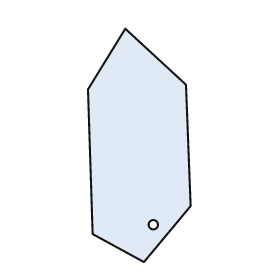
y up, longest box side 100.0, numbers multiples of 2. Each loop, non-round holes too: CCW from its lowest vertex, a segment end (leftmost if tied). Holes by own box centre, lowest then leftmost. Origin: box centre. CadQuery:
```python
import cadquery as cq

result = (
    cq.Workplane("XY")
    .moveTo(2.0, -50.0)
    .lineTo(22.0, -26.0)
    .lineTo(20.0, 26.0)
    .lineTo(-6.0, 50.0)
    .lineTo(-22.0, 24.0)
    .lineTo(-20.0, -38.0)
    .close()
    .moveTo(6.0, -34.0)
    .circle(2.0)
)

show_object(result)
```